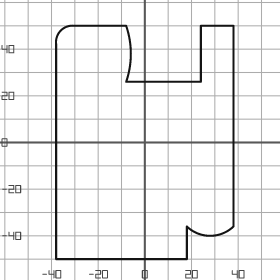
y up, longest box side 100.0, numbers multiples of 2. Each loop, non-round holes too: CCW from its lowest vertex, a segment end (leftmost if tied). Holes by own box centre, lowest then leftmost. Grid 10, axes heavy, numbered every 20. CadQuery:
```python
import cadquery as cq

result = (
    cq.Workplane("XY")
    .moveTo(-38.0, -50.0)
    .lineTo(18.0, -50.0)
    .lineTo(18.0, -36.0)
    .threePointArc((28.0, -40.0), (38.0, -36.0))
    .lineTo(38.0, 50.0)
    .lineTo(24.0, 50.0)
    .lineTo(24.0, 26.0)
    .lineTo(-8.0, 26.0)
    .threePointArc((-6.0, 38.0), (-8.0, 50.0))
    .lineTo(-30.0, 50.0)
    .threePointArc((-36.0, 48.0), (-38.0, 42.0))
    .close()
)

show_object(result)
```